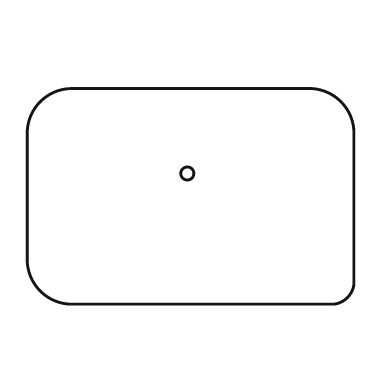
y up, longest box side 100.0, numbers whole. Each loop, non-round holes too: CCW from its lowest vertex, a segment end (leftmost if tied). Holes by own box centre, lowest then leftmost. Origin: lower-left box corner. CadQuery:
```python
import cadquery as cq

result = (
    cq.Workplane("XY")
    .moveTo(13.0, 0.0)
    .lineTo(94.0, 0.0)
    .threePointArc((98.0, 2.0), (100.0, 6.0))
    .lineTo(100.0, 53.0)
    .threePointArc((96.0, 62.0), (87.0, 66.0))
    .lineTo(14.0, 66.0)
    .threePointArc((4.0, 62.0), (0.0, 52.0))
    .lineTo(0.0, 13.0)
    .threePointArc((4.0, 4.0), (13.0, 0.0))
    .close()
    .moveTo(49.0, 40.0)
    .circle(2.0)
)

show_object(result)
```